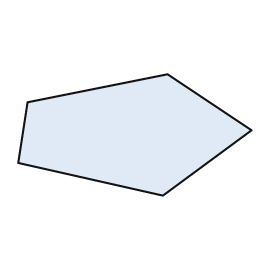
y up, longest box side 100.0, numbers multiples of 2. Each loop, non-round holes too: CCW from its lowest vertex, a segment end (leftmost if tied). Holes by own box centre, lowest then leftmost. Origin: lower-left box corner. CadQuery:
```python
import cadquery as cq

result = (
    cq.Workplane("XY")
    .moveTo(62.0, 0.0)
    .lineTo(100.0, 28.0)
    .lineTo(64.0, 52.0)
    .lineTo(4.0, 40.0)
    .lineTo(0.0, 14.0)
    .close()
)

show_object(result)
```